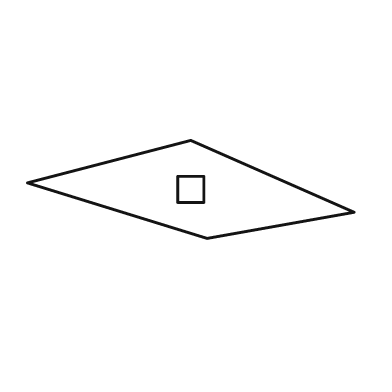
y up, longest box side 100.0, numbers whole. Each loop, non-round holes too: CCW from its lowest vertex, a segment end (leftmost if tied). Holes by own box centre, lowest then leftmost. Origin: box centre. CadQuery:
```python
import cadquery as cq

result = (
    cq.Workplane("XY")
    .moveTo(5.0, -15.0)
    .lineTo(50.0, -7.0)
    .lineTo(0.0, 15.0)
    .lineTo(-50.0, 2.0)
    .close()
    .moveTo(-4.0, -4.0)
    .lineTo(4.0, -4.0)
    .lineTo(4.0, 4.0)
    .lineTo(-4.0, 4.0)
    .close()
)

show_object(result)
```